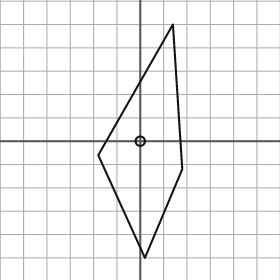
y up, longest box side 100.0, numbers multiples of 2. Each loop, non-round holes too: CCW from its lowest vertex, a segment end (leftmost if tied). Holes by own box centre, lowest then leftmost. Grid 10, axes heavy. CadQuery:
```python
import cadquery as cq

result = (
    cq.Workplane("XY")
    .moveTo(2.0, -50.0)
    .lineTo(18.0, -12.0)
    .lineTo(14.0, 50.0)
    .lineTo(-18.0, -6.0)
    .close()
    .moveTo(0.0, 0.0)
    .circle(2.0)
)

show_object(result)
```